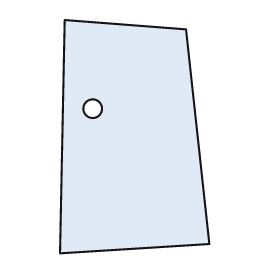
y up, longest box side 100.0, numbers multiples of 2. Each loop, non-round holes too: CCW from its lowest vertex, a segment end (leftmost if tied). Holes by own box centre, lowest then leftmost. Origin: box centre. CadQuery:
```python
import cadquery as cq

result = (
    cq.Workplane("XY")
    .moveTo(-32.0, -50.0)
    .lineTo(32.0, -46.0)
    .lineTo(22.0, 46.0)
    .lineTo(-30.0, 50.0)
    .close()
    .moveTo(-18.0, 12.0)
    .circle(4.0)
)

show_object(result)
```